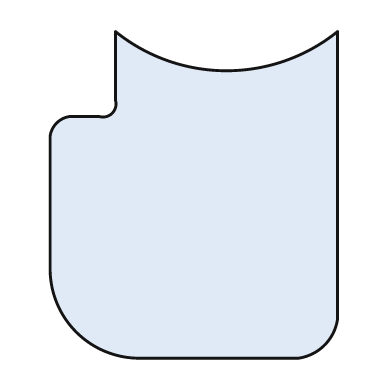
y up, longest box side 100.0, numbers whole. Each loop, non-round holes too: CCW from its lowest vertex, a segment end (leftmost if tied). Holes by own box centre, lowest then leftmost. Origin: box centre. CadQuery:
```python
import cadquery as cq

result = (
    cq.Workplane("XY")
    .moveTo(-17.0, -50.0)
    .lineTo(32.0, -50.0)
    .threePointArc((40.0, -46.0), (44.0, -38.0))
    .lineTo(44.0, 50.0)
    .threePointArc((10.0, 38.0), (-24.0, 50.0))
    .lineTo(-24.0, 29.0)
    .threePointArc((-25.0, 25.0), (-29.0, 24.0))
    .lineTo(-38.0, 24.0)
    .threePointArc((-42.0, 22.0), (-44.0, 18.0))
    .lineTo(-44.0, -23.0)
    .threePointArc((-36.0, -42.0), (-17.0, -50.0))
    .close()
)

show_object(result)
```